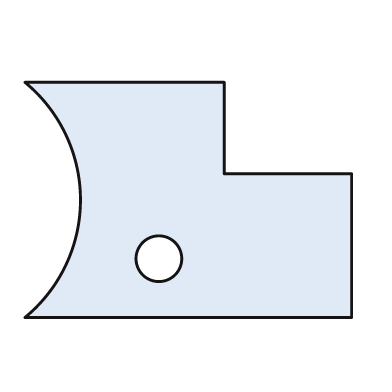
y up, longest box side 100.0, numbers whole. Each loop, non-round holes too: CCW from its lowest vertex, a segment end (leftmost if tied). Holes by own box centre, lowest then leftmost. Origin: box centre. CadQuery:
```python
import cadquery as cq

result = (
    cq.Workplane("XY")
    .moveTo(-50.0, -36.0)
    .lineTo(50.0, -36.0)
    .lineTo(50.0, 8.0)
    .lineTo(11.0, 8.0)
    .lineTo(11.0, 36.0)
    .lineTo(-50.0, 36.0)
    .threePointArc((-33.0, 0.0), (-50.0, -36.0))
    .close()
    .moveTo(-9.0, -18.0)
    .circle(7.0)
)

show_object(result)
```